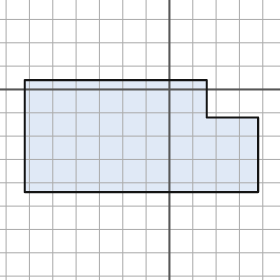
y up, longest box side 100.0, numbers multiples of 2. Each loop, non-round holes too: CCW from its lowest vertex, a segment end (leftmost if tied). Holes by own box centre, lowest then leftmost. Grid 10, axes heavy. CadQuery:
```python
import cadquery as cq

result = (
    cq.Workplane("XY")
    .moveTo(-62.0, -44.0)
    .lineTo(38.0, -44.0)
    .lineTo(38.0, -12.0)
    .lineTo(16.0, -12.0)
    .lineTo(16.0, 4.0)
    .lineTo(-62.0, 4.0)
    .close()
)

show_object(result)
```